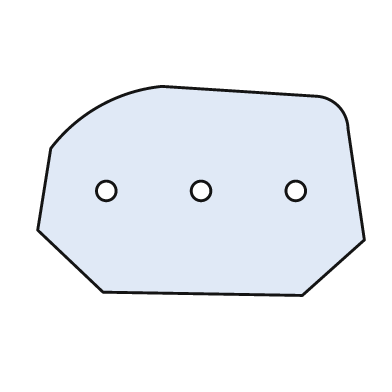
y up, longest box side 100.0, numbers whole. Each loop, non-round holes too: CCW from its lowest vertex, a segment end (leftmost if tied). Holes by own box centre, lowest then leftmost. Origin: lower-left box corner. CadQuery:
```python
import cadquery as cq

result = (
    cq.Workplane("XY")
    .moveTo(81.0, 0.0)
    .lineTo(100.0, 17.0)
    .lineTo(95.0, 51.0)
    .threePointArc((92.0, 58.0), (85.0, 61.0))
    .lineTo(38.0, 64.0)
    .threePointArc((19.0, 58.0), (4.0, 45.0))
    .lineTo(0.0, 20.0)
    .lineTo(20.0, 1.0)
    .close()
    .moveTo(21.0, 32.0)
    .circle(3.0)
    .moveTo(50.0, 32.0)
    .circle(3.0)
    .moveTo(79.0, 32.0)
    .circle(3.0)
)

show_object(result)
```